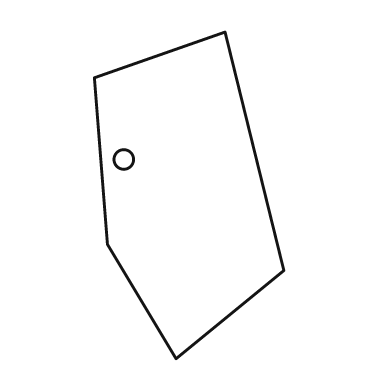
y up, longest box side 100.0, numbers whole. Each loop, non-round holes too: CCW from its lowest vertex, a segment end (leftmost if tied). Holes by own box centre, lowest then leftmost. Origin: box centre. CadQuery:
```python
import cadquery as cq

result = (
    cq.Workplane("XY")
    .moveTo(-4.0, -50.0)
    .lineTo(29.0, -23.0)
    .lineTo(11.0, 50.0)
    .lineTo(-29.0, 36.0)
    .lineTo(-25.0, -15.0)
    .close()
    .moveTo(-20.0, 11.0)
    .circle(3.0)
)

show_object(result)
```